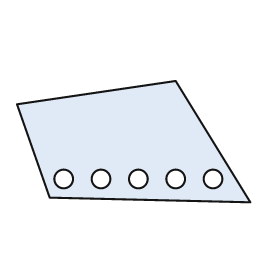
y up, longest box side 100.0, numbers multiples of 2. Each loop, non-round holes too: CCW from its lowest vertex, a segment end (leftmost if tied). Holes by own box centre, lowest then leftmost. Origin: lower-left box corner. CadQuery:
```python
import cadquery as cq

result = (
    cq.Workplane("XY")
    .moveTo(100.0, 0.0)
    .lineTo(68.0, 52.0)
    .lineTo(0.0, 42.0)
    .lineTo(14.0, 2.0)
    .close()
    .moveTo(20.0, 10.0)
    .circle(4.0)
    .moveTo(36.0, 10.0)
    .circle(4.0)
    .moveTo(52.0, 10.0)
    .circle(4.0)
    .moveTo(68.0, 10.0)
    .circle(4.0)
    .moveTo(84.0, 10.0)
    .circle(4.0)
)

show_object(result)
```